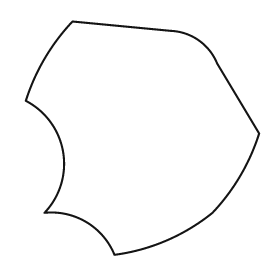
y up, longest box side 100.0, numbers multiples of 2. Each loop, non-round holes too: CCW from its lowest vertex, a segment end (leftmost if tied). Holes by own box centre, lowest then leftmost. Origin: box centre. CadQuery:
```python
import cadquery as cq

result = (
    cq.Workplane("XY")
    .moveTo(-12.0, -50.0)
    .threePointArc((10.0, -44.0), (30.0, -32.0))
    .threePointArc((42.0, -16.0), (50.0, 2.0))
    .lineTo(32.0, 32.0)
    .threePointArc((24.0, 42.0), (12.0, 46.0))
    .lineTo(-30.0, 50.0)
    .threePointArc((-42.0, 34.0), (-50.0, 16.0))
    .threePointArc((-34.0, -6.0), (-42.0, -32.0))
    .threePointArc((-24.0, -36.0), (-12.0, -50.0))
    .close()
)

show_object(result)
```